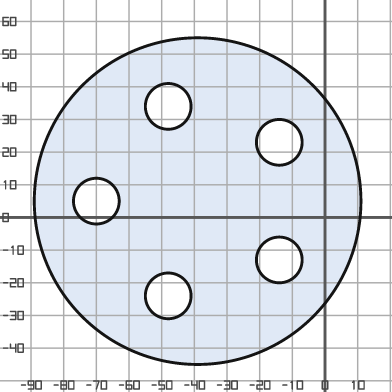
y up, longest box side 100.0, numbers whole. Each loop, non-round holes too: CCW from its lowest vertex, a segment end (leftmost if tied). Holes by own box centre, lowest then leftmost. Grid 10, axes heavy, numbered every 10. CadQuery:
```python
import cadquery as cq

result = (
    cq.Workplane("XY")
    .moveTo(-39.0, 5.0)
    .circle(50.0)
    .moveTo(-48.0, -24.0)
    .circle(7.0)
    .moveTo(-14.0, -13.0)
    .circle(7.0)
    .moveTo(-70.0, 5.0)
    .circle(7.0)
    .moveTo(-14.0, 23.0)
    .circle(7.0)
    .moveTo(-48.0, 34.0)
    .circle(7.0)
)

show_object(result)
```